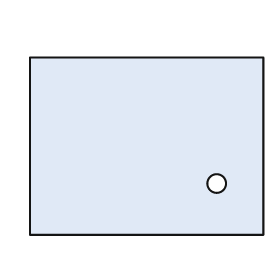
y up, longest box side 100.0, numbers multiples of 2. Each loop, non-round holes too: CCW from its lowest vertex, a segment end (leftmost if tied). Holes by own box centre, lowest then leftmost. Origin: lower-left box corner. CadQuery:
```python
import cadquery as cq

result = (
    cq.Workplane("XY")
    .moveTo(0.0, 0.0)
    .lineTo(100.0, 0.0)
    .lineTo(100.0, 76.0)
    .lineTo(0.0, 76.0)
    .close()
    .moveTo(80.0, 22.0)
    .circle(4.0)
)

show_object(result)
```